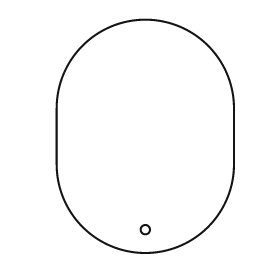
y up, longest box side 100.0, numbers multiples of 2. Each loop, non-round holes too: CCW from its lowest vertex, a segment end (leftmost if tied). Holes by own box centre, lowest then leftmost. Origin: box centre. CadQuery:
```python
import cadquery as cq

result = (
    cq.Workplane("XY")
    .moveTo(-38.0, -12.0)
    .threePointArc((0.0, -50.0), (38.0, -12.0))
    .lineTo(38.0, 12.0)
    .threePointArc((0.0, 50.0), (-38.0, 12.0))
    .close()
    .moveTo(0.0, -40.0)
    .circle(2.0)
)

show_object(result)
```